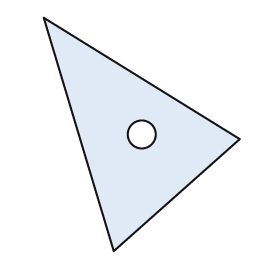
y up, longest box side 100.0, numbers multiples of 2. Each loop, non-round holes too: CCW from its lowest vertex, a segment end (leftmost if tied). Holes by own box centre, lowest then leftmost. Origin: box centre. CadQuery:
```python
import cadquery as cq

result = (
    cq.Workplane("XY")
    .moveTo(-12.0, -50.0)
    .lineTo(42.0, -2.0)
    .lineTo(-42.0, 50.0)
    .close()
    .moveTo(0.0, 0.0)
    .circle(6.0)
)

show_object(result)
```